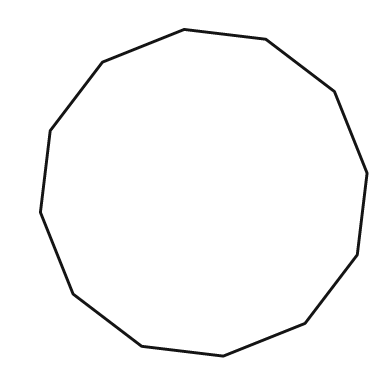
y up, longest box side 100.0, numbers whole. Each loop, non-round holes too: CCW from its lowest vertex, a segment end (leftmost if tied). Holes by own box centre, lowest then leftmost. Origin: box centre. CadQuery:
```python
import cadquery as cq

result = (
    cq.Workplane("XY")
    .moveTo(6.0, -50.0)
    .lineTo(31.0, -40.0)
    .lineTo(47.0, -19.0)
    .lineTo(50.0, 6.0)
    .lineTo(40.0, 31.0)
    .lineTo(19.0, 47.0)
    .lineTo(-6.0, 50.0)
    .lineTo(-31.0, 40.0)
    .lineTo(-47.0, 19.0)
    .lineTo(-50.0, -6.0)
    .lineTo(-40.0, -31.0)
    .lineTo(-19.0, -47.0)
    .close()
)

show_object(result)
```